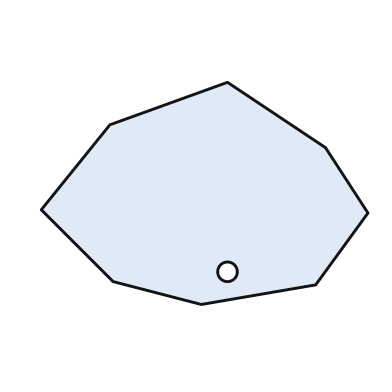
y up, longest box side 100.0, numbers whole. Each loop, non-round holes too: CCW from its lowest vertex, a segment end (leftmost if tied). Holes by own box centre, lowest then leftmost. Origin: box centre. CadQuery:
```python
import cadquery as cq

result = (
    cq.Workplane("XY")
    .moveTo(-1.0, -34.0)
    .lineTo(34.0, -28.0)
    .lineTo(50.0, -6.0)
    .lineTo(37.0, 14.0)
    .lineTo(7.0, 34.0)
    .lineTo(-29.0, 21.0)
    .lineTo(-50.0, -5.0)
    .lineTo(-28.0, -27.0)
    .close()
    .moveTo(7.0, -24.0)
    .circle(3.0)
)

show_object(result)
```